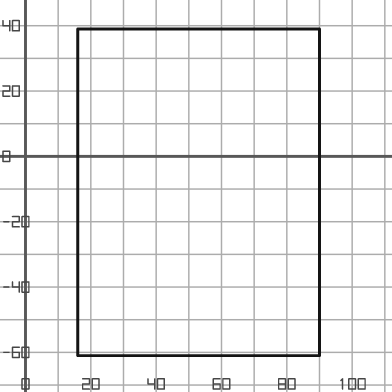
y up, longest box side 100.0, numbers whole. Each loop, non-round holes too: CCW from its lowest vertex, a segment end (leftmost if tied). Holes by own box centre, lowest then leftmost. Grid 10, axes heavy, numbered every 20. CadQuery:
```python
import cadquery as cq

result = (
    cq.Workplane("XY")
    .moveTo(16.0, -61.0)
    .lineTo(90.0, -61.0)
    .lineTo(90.0, 39.0)
    .lineTo(16.0, 39.0)
    .close()
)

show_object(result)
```